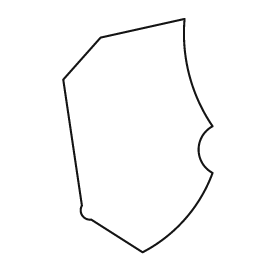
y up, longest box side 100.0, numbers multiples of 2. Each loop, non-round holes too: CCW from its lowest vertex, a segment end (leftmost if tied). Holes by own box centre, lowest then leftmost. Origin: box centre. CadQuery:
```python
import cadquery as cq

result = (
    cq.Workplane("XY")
    .moveTo(2.0, -50.0)
    .threePointArc((20.0, -36.0), (32.0, -16.0))
    .threePointArc((26.0, -6.0), (32.0, 4.0))
    .threePointArc((22.0, 26.0), (20.0, 50.0))
    .lineTo(-16.0, 42.0)
    .lineTo(-32.0, 24.0)
    .lineTo(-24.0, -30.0)
    .threePointArc((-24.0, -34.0), (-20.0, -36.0))
    .close()
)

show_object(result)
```